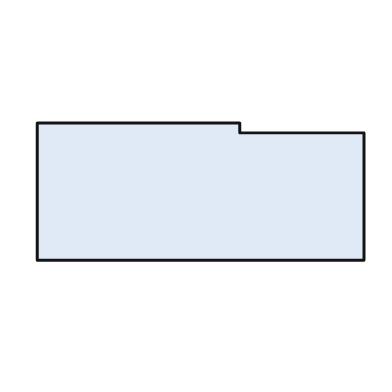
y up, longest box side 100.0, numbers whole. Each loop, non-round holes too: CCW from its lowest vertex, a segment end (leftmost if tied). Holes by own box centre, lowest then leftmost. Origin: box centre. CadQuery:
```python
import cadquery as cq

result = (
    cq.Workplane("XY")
    .moveTo(-50.0, -21.0)
    .lineTo(50.0, -21.0)
    .lineTo(50.0, 18.0)
    .lineTo(12.0, 18.0)
    .lineTo(12.0, 21.0)
    .lineTo(-50.0, 21.0)
    .close()
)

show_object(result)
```